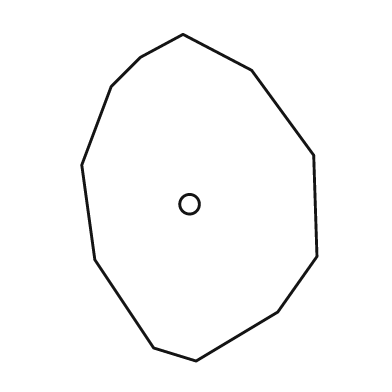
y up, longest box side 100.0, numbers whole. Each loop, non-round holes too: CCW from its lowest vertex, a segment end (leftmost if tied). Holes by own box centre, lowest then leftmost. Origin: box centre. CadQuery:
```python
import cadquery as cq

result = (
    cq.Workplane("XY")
    .moveTo(-1.0, -50.0)
    .lineTo(24.0, -35.0)
    .lineTo(36.0, -18.0)
    .lineTo(35.0, 13.0)
    .lineTo(16.0, 39.0)
    .lineTo(-5.0, 50.0)
    .lineTo(-18.0, 43.0)
    .lineTo(-27.0, 34.0)
    .lineTo(-36.0, 10.0)
    .lineTo(-32.0, -19.0)
    .lineTo(-14.0, -46.0)
    .close()
    .moveTo(-3.0, -2.0)
    .circle(3.0)
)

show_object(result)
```